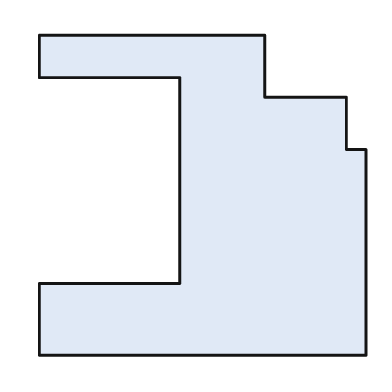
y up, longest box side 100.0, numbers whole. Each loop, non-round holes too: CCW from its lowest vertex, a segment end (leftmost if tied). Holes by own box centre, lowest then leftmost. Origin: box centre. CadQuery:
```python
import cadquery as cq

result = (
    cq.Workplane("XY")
    .moveTo(-50.0, -49.0)
    .lineTo(50.0, -49.0)
    .lineTo(50.0, 14.0)
    .lineTo(44.0, 14.0)
    .lineTo(44.0, 30.0)
    .lineTo(19.0, 30.0)
    .lineTo(19.0, 49.0)
    .lineTo(-50.0, 49.0)
    .lineTo(-50.0, 36.0)
    .lineTo(-7.0, 36.0)
    .lineTo(-7.0, -27.0)
    .lineTo(-50.0, -27.0)
    .close()
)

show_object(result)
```